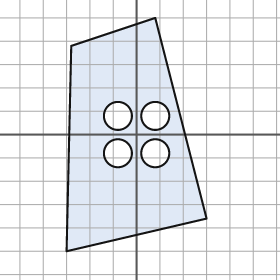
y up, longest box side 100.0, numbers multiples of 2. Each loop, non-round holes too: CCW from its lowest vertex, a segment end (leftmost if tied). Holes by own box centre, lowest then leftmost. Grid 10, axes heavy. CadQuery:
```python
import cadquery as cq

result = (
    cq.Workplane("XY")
    .moveTo(-30.0, -50.0)
    .lineTo(30.0, -36.0)
    .lineTo(8.0, 50.0)
    .lineTo(-28.0, 38.0)
    .close()
    .moveTo(-8.0, -8.0)
    .circle(6.0)
    .moveTo(8.0, -8.0)
    .circle(6.0)
    .moveTo(-8.0, 8.0)
    .circle(6.0)
    .moveTo(8.0, 8.0)
    .circle(6.0)
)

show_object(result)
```